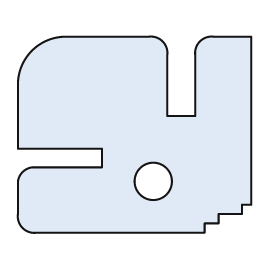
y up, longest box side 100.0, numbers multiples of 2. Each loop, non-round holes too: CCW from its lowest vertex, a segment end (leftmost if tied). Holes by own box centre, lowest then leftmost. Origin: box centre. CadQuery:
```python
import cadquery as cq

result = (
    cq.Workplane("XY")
    .moveTo(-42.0, -42.0)
    .lineTo(30.0, -42.0)
    .lineTo(30.0, -38.0)
    .lineTo(36.0, -38.0)
    .lineTo(36.0, -34.0)
    .lineTo(46.0, -34.0)
    .lineTo(46.0, -30.0)
    .lineTo(50.0, -30.0)
    .lineTo(50.0, 42.0)
    .lineTo(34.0, 42.0)
    .threePointArc((28.0, 40.0), (26.0, 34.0))
    .lineTo(26.0, 8.0)
    .lineTo(14.0, 8.0)
    .lineTo(14.0, 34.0)
    .threePointArc((12.0, 40.0), (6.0, 42.0))
    .lineTo(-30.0, 42.0)
    .threePointArc((-44.0, 36.0), (-50.0, 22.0))
    .lineTo(-50.0, -6.0)
    .lineTo(-14.0, -6.0)
    .lineTo(-14.0, -14.0)
    .lineTo(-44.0, -14.0)
    .threePointArc((-48.0, -16.0), (-50.0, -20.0))
    .lineTo(-50.0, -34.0)
    .threePointArc((-48.0, -40.0), (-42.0, -42.0))
    .close()
    .moveTo(8.0, -20.0)
    .circle(8.0)
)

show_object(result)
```